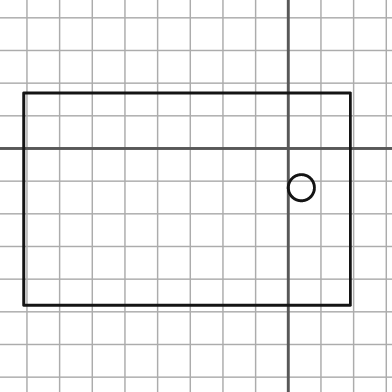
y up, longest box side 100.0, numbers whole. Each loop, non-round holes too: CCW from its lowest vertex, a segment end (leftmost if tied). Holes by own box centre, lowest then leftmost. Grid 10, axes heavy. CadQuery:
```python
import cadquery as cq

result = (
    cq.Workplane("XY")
    .moveTo(-81.0, -48.0)
    .lineTo(19.0, -48.0)
    .lineTo(19.0, 17.0)
    .lineTo(-81.0, 17.0)
    .close()
    .moveTo(4.0, -12.0)
    .circle(4.0)
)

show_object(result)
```